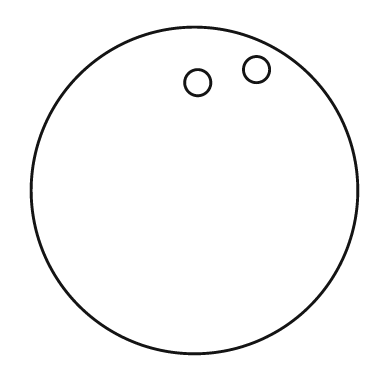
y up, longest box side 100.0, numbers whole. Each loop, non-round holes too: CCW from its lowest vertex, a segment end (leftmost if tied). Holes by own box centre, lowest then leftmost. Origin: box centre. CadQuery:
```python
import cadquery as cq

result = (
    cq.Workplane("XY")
    .moveTo(0.0, 0.0)
    .circle(50.0)
    .moveTo(1.0, 33.0)
    .circle(4.0)
    .moveTo(19.0, 37.0)
    .circle(4.0)
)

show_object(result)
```